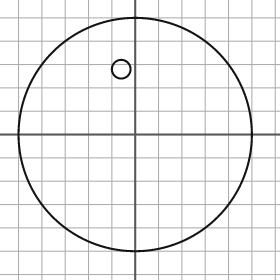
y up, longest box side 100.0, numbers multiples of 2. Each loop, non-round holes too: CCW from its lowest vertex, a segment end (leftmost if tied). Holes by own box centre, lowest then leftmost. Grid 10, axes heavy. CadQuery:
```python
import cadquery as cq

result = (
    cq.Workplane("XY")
    .moveTo(0.0, 0.0)
    .circle(50.0)
    .moveTo(-6.0, 28.0)
    .circle(4.0)
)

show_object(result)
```